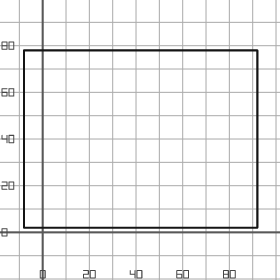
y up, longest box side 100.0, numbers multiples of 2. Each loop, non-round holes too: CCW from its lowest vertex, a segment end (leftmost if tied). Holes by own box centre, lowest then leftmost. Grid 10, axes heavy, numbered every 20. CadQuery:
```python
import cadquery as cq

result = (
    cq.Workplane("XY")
    .moveTo(-8.0, 2.0)
    .lineTo(92.0, 2.0)
    .lineTo(92.0, 78.0)
    .lineTo(-8.0, 78.0)
    .close()
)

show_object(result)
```